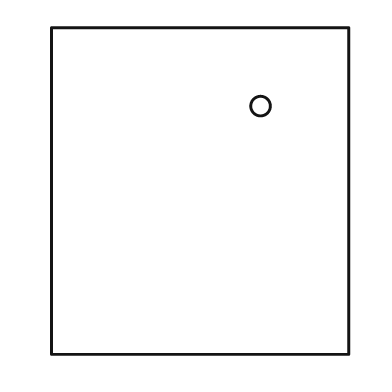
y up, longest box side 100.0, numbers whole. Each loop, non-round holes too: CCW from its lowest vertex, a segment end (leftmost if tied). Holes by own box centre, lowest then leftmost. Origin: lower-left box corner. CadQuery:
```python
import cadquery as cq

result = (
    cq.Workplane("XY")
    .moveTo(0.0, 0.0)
    .lineTo(91.0, 0.0)
    .lineTo(91.0, 100.0)
    .lineTo(0.0, 100.0)
    .close()
    .moveTo(64.0, 76.0)
    .circle(3.0)
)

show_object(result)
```